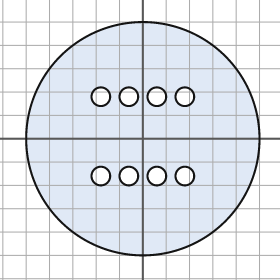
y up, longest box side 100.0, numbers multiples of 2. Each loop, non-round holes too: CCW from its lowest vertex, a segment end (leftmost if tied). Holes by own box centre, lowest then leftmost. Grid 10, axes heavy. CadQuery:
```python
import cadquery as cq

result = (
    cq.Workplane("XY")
    .moveTo(0.0, 0.0)
    .circle(50.0)
    .moveTo(-18.0, -16.0)
    .circle(4.0)
    .moveTo(-6.0, -16.0)
    .circle(4.0)
    .moveTo(6.0, -16.0)
    .circle(4.0)
    .moveTo(18.0, -16.0)
    .circle(4.0)
    .moveTo(-18.0, 18.0)
    .circle(4.0)
    .moveTo(-6.0, 18.0)
    .circle(4.0)
    .moveTo(6.0, 18.0)
    .circle(4.0)
    .moveTo(18.0, 18.0)
    .circle(4.0)
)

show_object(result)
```